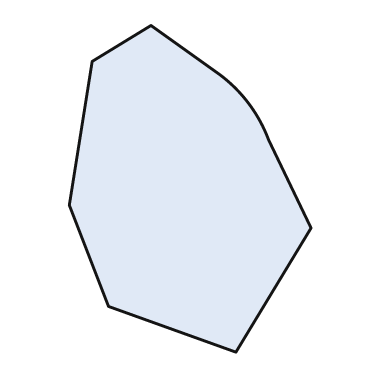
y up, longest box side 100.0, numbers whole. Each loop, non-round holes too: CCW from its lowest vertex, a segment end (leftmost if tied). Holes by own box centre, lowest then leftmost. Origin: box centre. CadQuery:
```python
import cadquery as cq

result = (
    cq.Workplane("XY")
    .moveTo(14.0, -50.0)
    .lineTo(37.0, -12.0)
    .lineTo(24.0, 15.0)
    .threePointArc((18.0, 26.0), (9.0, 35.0))
    .lineTo(-12.0, 50.0)
    .lineTo(-30.0, 39.0)
    .lineTo(-37.0, -5.0)
    .lineTo(-25.0, -36.0)
    .close()
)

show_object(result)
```